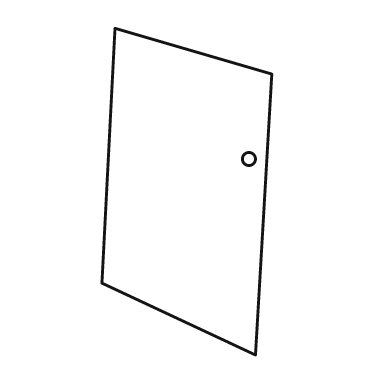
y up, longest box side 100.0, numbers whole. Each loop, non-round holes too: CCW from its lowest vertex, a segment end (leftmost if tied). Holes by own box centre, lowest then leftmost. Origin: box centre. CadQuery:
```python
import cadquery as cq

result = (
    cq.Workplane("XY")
    .moveTo(21.0, -50.0)
    .lineTo(26.0, 36.0)
    .lineTo(-22.0, 50.0)
    .lineTo(-26.0, -28.0)
    .close()
    .moveTo(19.0, 10.0)
    .circle(2.0)
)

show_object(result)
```